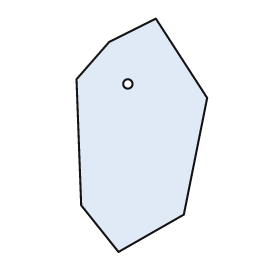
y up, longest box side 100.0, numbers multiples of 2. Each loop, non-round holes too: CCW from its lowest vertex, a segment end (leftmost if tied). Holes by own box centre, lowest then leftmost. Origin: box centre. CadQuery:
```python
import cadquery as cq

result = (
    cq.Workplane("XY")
    .moveTo(-10.0, -50.0)
    .lineTo(18.0, -34.0)
    .lineTo(28.0, 16.0)
    .lineTo(6.0, 50.0)
    .lineTo(-14.0, 40.0)
    .lineTo(-28.0, 24.0)
    .lineTo(-26.0, -30.0)
    .close()
    .moveTo(-6.0, 22.0)
    .circle(2.0)
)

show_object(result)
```